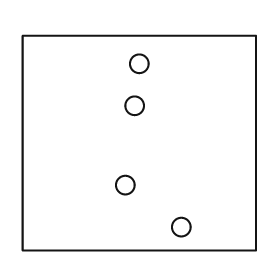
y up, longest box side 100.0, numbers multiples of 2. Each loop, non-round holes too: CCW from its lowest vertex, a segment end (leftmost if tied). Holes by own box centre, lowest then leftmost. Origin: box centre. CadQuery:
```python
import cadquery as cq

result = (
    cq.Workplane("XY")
    .moveTo(-50.0, -46.0)
    .lineTo(50.0, -46.0)
    .lineTo(50.0, 46.0)
    .lineTo(-50.0, 46.0)
    .close()
    .moveTo(18.0, -36.0)
    .circle(4.0)
    .moveTo(-6.0, -18.0)
    .circle(4.0)
    .moveTo(-2.0, 16.0)
    .circle(4.0)
    .moveTo(0.0, 34.0)
    .circle(4.0)
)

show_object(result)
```